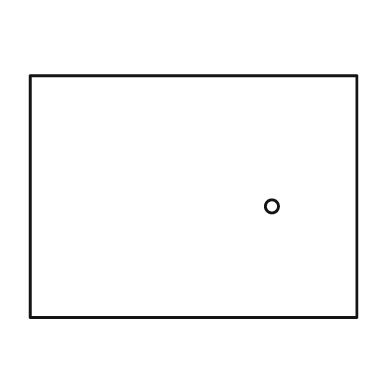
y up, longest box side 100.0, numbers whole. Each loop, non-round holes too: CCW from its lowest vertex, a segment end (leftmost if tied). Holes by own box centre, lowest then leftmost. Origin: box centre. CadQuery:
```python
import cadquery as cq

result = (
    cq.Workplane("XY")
    .moveTo(-50.0, -37.0)
    .lineTo(50.0, -37.0)
    .lineTo(50.0, 37.0)
    .lineTo(-50.0, 37.0)
    .close()
    .moveTo(24.0, -3.0)
    .circle(2.0)
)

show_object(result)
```